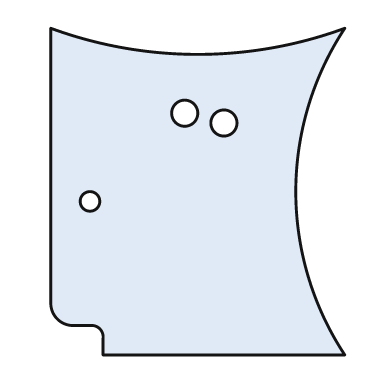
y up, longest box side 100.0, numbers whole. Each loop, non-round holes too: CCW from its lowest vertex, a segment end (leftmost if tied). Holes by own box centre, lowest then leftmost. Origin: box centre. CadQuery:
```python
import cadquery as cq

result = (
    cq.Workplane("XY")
    .moveTo(-29.0, -50.0)
    .lineTo(45.0, -50.0)
    .threePointArc((30.0, 0.0), (45.0, 50.0))
    .threePointArc((0.0, 42.0), (-45.0, 50.0))
    .lineTo(-45.0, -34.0)
    .threePointArc((-43.0, -39.0), (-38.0, -41.0))
    .lineTo(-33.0, -41.0)
    .threePointArc((-30.0, -42.0), (-29.0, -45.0))
    .close()
    .moveTo(-33.0, -3.0)
    .circle(3.0)
    .moveTo(8.0, 21.0)
    .circle(4.0)
    .moveTo(-4.0, 24.0)
    .circle(4.0)
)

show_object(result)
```